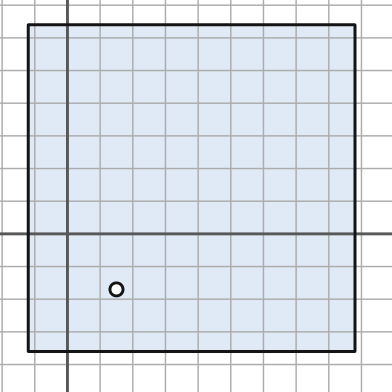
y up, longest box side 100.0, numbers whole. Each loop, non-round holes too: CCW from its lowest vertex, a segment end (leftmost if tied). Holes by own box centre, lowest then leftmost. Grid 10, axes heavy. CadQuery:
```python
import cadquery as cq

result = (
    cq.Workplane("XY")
    .moveTo(-12.0, -36.0)
    .lineTo(88.0, -36.0)
    .lineTo(88.0, 64.0)
    .lineTo(-12.0, 64.0)
    .close()
    .moveTo(15.0, -17.0)
    .circle(2.0)
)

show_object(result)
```